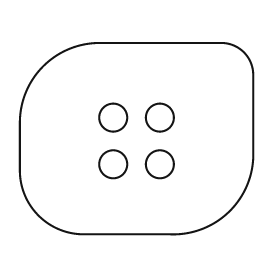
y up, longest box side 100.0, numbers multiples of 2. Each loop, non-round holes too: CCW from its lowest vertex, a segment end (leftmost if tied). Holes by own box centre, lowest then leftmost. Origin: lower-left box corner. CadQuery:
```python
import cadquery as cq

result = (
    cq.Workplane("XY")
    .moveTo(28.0, 0.0)
    .lineTo(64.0, 0.0)
    .threePointArc((90.0, 10.0), (100.0, 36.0))
    .lineTo(100.0, 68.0)
    .threePointArc((96.0, 78.0), (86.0, 82.0))
    .lineTo(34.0, 82.0)
    .threePointArc((10.0, 72.0), (0.0, 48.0))
    .lineTo(0.0, 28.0)
    .threePointArc((8.0, 8.0), (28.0, 0.0))
    .close()
    .moveTo(40.0, 30.0)
    .circle(6.0)
    .moveTo(60.0, 30.0)
    .circle(6.0)
    .moveTo(40.0, 50.0)
    .circle(6.0)
    .moveTo(60.0, 50.0)
    .circle(6.0)
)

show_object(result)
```